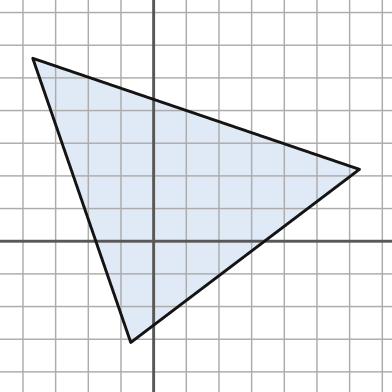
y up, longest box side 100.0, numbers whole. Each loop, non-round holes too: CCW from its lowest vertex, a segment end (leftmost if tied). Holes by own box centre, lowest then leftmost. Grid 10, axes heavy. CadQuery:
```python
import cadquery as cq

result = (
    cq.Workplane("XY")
    .moveTo(-7.0, -31.0)
    .lineTo(63.0, 22.0)
    .lineTo(-37.0, 56.0)
    .close()
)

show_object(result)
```